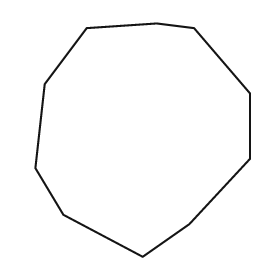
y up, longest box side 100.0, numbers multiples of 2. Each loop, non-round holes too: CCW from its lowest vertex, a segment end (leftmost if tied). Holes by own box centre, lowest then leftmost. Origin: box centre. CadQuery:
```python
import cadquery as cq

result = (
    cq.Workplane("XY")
    .moveTo(0.0, -50.0)
    .lineTo(20.0, -36.0)
    .lineTo(46.0, -8.0)
    .lineTo(46.0, 20.0)
    .lineTo(22.0, 48.0)
    .lineTo(6.0, 50.0)
    .lineTo(-24.0, 48.0)
    .lineTo(-42.0, 24.0)
    .lineTo(-46.0, -12.0)
    .lineTo(-34.0, -32.0)
    .close()
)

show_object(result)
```